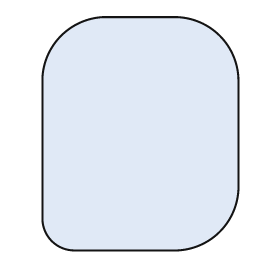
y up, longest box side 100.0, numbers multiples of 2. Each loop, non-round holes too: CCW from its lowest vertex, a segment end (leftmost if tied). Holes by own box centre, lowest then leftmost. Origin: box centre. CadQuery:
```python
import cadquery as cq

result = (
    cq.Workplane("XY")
    .moveTo(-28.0, -50.0)
    .lineTo(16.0, -50.0)
    .threePointArc((34.0, -42.0), (42.0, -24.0))
    .lineTo(42.0, 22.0)
    .threePointArc((34.0, 42.0), (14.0, 50.0))
    .lineTo(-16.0, 50.0)
    .threePointArc((-34.0, 42.0), (-42.0, 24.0))
    .lineTo(-42.0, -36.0)
    .threePointArc((-38.0, -46.0), (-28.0, -50.0))
    .close()
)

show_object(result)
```